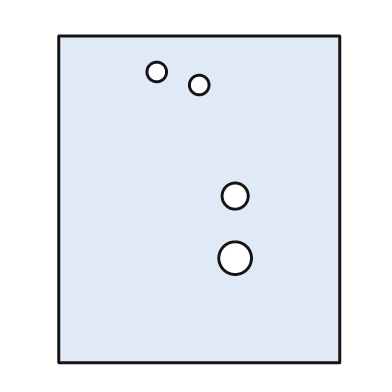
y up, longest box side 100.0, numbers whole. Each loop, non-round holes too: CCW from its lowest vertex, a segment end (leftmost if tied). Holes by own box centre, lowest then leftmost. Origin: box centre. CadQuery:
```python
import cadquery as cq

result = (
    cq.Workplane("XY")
    .moveTo(-43.0, -50.0)
    .lineTo(43.0, -50.0)
    .lineTo(43.0, 50.0)
    .lineTo(-43.0, 50.0)
    .close()
    .moveTo(11.0, -18.0)
    .circle(5.0)
    .moveTo(11.0, 1.0)
    .circle(4.0)
    .moveTo(0.0, 35.0)
    .circle(3.0)
    .moveTo(-13.0, 39.0)
    .circle(3.0)
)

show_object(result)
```